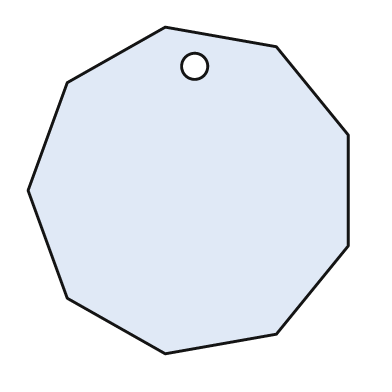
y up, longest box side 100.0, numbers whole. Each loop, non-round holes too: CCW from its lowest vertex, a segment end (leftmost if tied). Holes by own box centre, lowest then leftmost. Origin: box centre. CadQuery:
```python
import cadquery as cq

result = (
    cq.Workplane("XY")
    .moveTo(-7.0, -50.0)
    .lineTo(27.0, -44.0)
    .lineTo(49.0, -17.0)
    .lineTo(49.0, 17.0)
    .lineTo(27.0, 44.0)
    .lineTo(-7.0, 50.0)
    .lineTo(-37.0, 33.0)
    .lineTo(-49.0, 0.0)
    .lineTo(-37.0, -33.0)
    .close()
    .moveTo(2.0, 38.0)
    .circle(4.0)
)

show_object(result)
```